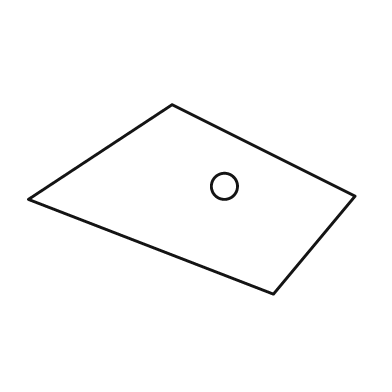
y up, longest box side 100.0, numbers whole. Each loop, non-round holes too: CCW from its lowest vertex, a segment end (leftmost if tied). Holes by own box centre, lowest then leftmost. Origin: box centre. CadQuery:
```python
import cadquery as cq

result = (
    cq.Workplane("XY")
    .moveTo(25.0, -29.0)
    .lineTo(50.0, 1.0)
    .lineTo(-6.0, 29.0)
    .lineTo(-50.0, 0.0)
    .close()
    .moveTo(10.0, 4.0)
    .circle(4.0)
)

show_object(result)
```